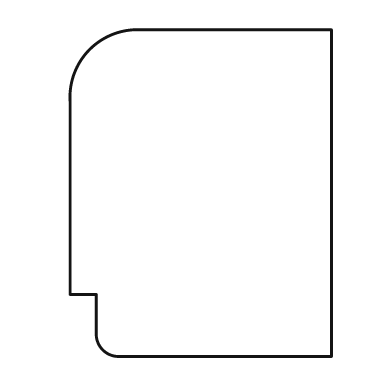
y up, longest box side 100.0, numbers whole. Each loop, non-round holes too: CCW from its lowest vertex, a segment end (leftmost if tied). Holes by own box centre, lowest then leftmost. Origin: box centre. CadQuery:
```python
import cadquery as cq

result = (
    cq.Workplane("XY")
    .moveTo(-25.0, -50.0)
    .lineTo(40.0, -50.0)
    .lineTo(40.0, 50.0)
    .lineTo(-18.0, 50.0)
    .threePointArc((-34.0, 44.0), (-40.0, 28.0))
    .lineTo(-40.0, -31.0)
    .lineTo(-32.0, -31.0)
    .lineTo(-32.0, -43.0)
    .threePointArc((-30.0, -48.0), (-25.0, -50.0))
    .close()
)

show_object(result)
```